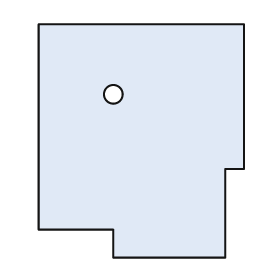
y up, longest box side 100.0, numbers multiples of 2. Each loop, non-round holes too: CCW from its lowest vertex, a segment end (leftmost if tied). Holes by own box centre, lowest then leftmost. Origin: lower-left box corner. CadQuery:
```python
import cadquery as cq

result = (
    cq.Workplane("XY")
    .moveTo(32.0, 0.0)
    .lineTo(80.0, 0.0)
    .lineTo(80.0, 38.0)
    .lineTo(88.0, 38.0)
    .lineTo(88.0, 100.0)
    .lineTo(0.0, 100.0)
    .lineTo(0.0, 12.0)
    .lineTo(32.0, 12.0)
    .close()
    .moveTo(32.0, 70.0)
    .circle(4.0)
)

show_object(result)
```